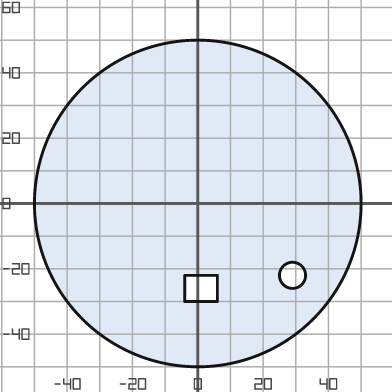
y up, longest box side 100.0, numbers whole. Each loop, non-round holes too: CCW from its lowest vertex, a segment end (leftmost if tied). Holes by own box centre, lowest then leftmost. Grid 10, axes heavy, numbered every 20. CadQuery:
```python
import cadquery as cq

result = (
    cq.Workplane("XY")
    .moveTo(0.0, 0.0)
    .circle(50.0)
    .moveTo(-4.0, -30.0)
    .lineTo(6.0, -30.0)
    .lineTo(6.0, -22.0)
    .lineTo(-4.0, -22.0)
    .close()
    .moveTo(29.0, -22.0)
    .circle(4.0)
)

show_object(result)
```